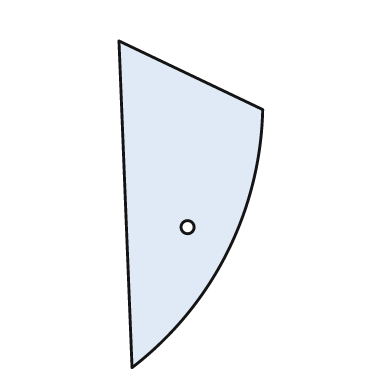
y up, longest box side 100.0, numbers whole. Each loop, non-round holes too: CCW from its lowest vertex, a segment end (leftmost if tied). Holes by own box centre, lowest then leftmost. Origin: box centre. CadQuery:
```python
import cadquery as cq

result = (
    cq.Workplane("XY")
    .moveTo(-18.0, -50.0)
    .threePointArc((11.0, -15.0), (22.0, 29.0))
    .lineTo(-22.0, 50.0)
    .close()
    .moveTo(-1.0, -7.0)
    .circle(2.0)
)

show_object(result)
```